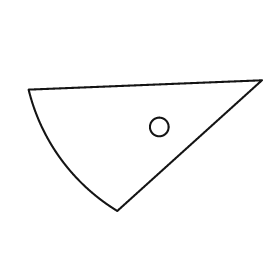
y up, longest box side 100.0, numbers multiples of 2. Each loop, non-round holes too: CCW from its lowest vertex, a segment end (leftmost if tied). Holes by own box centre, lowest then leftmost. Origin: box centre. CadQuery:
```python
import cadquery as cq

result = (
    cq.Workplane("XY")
    .moveTo(-12.0, -28.0)
    .lineTo(50.0, 28.0)
    .lineTo(-50.0, 24.0)
    .threePointArc((-36.0, -6.0), (-12.0, -28.0))
    .close()
    .moveTo(6.0, 8.0)
    .circle(4.0)
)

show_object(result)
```